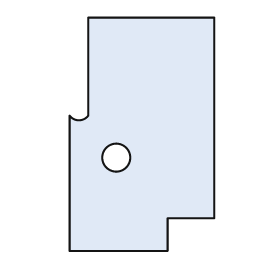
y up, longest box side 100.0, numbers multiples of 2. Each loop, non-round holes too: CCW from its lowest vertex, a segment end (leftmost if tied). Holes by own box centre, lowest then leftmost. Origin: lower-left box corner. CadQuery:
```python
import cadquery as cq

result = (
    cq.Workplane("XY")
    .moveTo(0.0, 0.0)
    .lineTo(42.0, 0.0)
    .lineTo(42.0, 14.0)
    .lineTo(62.0, 14.0)
    .lineTo(62.0, 100.0)
    .lineTo(8.0, 100.0)
    .lineTo(8.0, 58.0)
    .threePointArc((4.0, 56.0), (0.0, 58.0))
    .close()
    .moveTo(20.0, 40.0)
    .circle(6.0)
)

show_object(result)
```